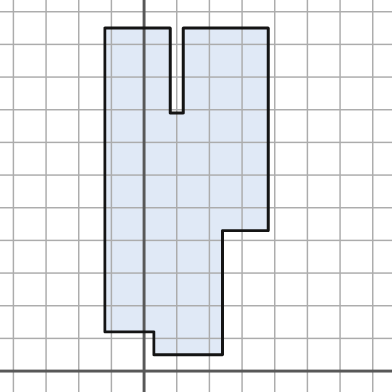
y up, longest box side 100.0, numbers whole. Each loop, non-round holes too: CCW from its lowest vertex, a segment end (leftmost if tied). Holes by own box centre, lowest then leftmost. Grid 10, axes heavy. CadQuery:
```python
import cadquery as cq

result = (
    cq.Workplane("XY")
    .moveTo(3.0, 5.0)
    .lineTo(24.0, 5.0)
    .lineTo(24.0, 43.0)
    .lineTo(38.0, 43.0)
    .lineTo(38.0, 105.0)
    .lineTo(12.0, 105.0)
    .lineTo(12.0, 79.0)
    .lineTo(8.0, 79.0)
    .lineTo(8.0, 105.0)
    .lineTo(-12.0, 105.0)
    .lineTo(-12.0, 12.0)
    .lineTo(3.0, 12.0)
    .close()
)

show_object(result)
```